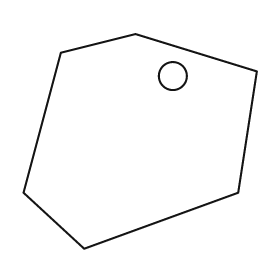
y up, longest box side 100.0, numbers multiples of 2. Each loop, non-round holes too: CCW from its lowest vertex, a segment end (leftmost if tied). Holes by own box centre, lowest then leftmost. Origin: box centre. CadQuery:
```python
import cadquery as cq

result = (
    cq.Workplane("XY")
    .moveTo(-24.0, -46.0)
    .lineTo(42.0, -22.0)
    .lineTo(50.0, 30.0)
    .lineTo(-2.0, 46.0)
    .lineTo(-34.0, 38.0)
    .lineTo(-50.0, -22.0)
    .close()
    .moveTo(14.0, 28.0)
    .circle(6.0)
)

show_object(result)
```